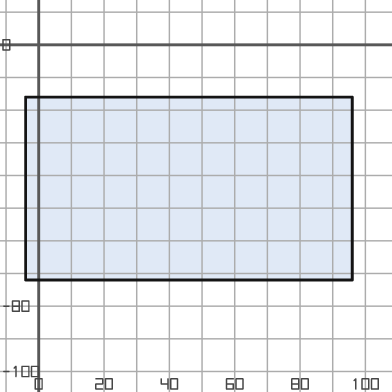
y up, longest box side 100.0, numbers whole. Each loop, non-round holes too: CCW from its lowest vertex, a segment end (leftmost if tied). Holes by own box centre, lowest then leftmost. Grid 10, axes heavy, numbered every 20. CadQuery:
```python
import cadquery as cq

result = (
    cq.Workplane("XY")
    .moveTo(-4.0, -72.0)
    .lineTo(96.0, -72.0)
    .lineTo(96.0, -16.0)
    .lineTo(-4.0, -16.0)
    .close()
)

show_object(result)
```